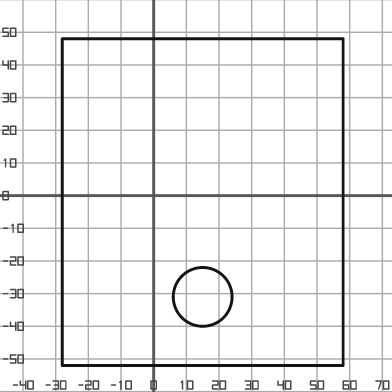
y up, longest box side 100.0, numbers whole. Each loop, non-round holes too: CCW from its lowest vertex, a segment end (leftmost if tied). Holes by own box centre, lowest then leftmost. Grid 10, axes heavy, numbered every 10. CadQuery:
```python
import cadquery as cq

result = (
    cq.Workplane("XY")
    .moveTo(-28.0, -52.0)
    .lineTo(58.0, -52.0)
    .lineTo(58.0, 48.0)
    .lineTo(-28.0, 48.0)
    .close()
    .moveTo(15.0, -31.0)
    .circle(9.0)
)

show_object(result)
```